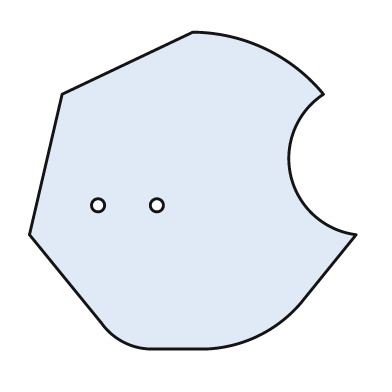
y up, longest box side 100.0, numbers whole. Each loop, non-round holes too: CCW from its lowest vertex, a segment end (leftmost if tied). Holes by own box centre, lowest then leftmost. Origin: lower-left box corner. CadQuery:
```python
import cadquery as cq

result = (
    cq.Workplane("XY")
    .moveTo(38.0, 0.0)
    .lineTo(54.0, 0.0)
    .threePointArc((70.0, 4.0), (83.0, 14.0))
    .lineTo(100.0, 35.0)
    .threePointArc((80.0, 53.0), (90.0, 78.0))
    .threePointArc((72.0, 92.0), (50.0, 97.0))
    .lineTo(10.0, 78.0)
    .lineTo(0.0, 35.0)
    .lineTo(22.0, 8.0)
    .threePointArc((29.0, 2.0), (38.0, 0.0))
    .close()
    .moveTo(21.0, 44.0)
    .circle(2.0)
    .moveTo(39.0, 44.0)
    .circle(2.0)
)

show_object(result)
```